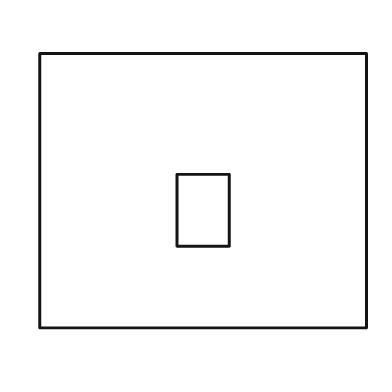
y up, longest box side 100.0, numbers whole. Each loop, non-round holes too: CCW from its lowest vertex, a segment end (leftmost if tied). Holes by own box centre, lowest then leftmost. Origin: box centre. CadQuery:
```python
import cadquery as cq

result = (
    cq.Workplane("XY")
    .moveTo(-50.0, -42.0)
    .lineTo(50.0, -42.0)
    .lineTo(50.0, 42.0)
    .lineTo(-50.0, 42.0)
    .close()
    .moveTo(-8.0, -17.0)
    .lineTo(8.0, -17.0)
    .lineTo(8.0, 5.0)
    .lineTo(-8.0, 5.0)
    .close()
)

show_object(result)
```